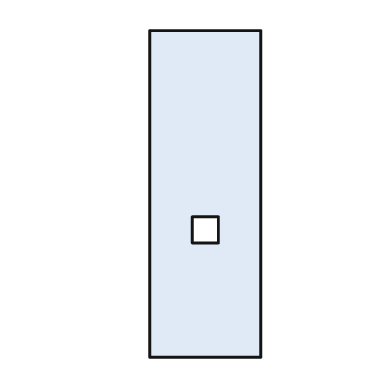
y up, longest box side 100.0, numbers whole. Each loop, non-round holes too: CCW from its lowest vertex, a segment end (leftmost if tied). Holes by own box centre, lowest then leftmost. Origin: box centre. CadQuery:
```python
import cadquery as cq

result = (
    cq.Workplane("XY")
    .moveTo(-17.0, -50.0)
    .lineTo(17.0, -50.0)
    .lineTo(17.0, 50.0)
    .lineTo(-17.0, 50.0)
    .close()
    .moveTo(-4.0, -15.0)
    .lineTo(4.0, -15.0)
    .lineTo(4.0, -7.0)
    .lineTo(-4.0, -7.0)
    .close()
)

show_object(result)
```